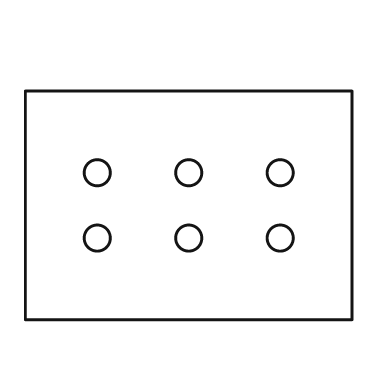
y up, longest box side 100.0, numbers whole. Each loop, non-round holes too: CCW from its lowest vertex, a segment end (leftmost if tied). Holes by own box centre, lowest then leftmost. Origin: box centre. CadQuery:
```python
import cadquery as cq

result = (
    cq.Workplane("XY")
    .moveTo(-50.0, -35.0)
    .lineTo(50.0, -35.0)
    .lineTo(50.0, 35.0)
    .lineTo(-50.0, 35.0)
    .close()
    .moveTo(-28.0, -10.0)
    .circle(4.0)
    .moveTo(0.0, -10.0)
    .circle(4.0)
    .moveTo(28.0, -10.0)
    .circle(4.0)
    .moveTo(-28.0, 10.0)
    .circle(4.0)
    .moveTo(0.0, 10.0)
    .circle(4.0)
    .moveTo(28.0, 10.0)
    .circle(4.0)
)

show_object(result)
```